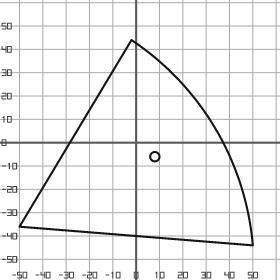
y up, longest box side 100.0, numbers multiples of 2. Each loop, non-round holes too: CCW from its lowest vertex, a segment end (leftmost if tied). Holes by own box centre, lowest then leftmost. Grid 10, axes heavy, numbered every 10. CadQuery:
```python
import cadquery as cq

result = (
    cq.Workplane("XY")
    .moveTo(50.0, -44.0)
    .threePointArc((34.0, 6.0), (-2.0, 44.0))
    .lineTo(-50.0, -36.0)
    .close()
    .moveTo(8.0, -6.0)
    .circle(2.0)
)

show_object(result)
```